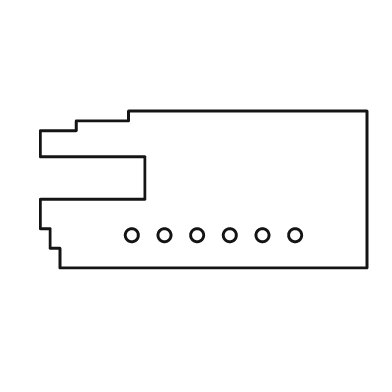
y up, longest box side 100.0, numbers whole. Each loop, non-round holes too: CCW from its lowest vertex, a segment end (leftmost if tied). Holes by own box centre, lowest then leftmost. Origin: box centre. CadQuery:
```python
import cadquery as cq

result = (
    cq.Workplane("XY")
    .moveTo(-44.0, -24.0)
    .lineTo(50.0, -24.0)
    .lineTo(50.0, 24.0)
    .lineTo(-23.0, 24.0)
    .lineTo(-23.0, 21.0)
    .lineTo(-39.0, 21.0)
    .lineTo(-39.0, 18.0)
    .lineTo(-50.0, 18.0)
    .lineTo(-50.0, 10.0)
    .lineTo(-18.0, 10.0)
    .lineTo(-18.0, -3.0)
    .lineTo(-50.0, -3.0)
    .lineTo(-50.0, -12.0)
    .lineTo(-47.0, -12.0)
    .lineTo(-47.0, -18.0)
    .lineTo(-44.0, -18.0)
    .close()
    .moveTo(-22.0, -14.0)
    .circle(2.0)
    .moveTo(-12.0, -14.0)
    .circle(2.0)
    .moveTo(-2.0, -14.0)
    .circle(2.0)
    .moveTo(8.0, -14.0)
    .circle(2.0)
    .moveTo(18.0, -14.0)
    .circle(2.0)
    .moveTo(28.0, -14.0)
    .circle(2.0)
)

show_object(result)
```